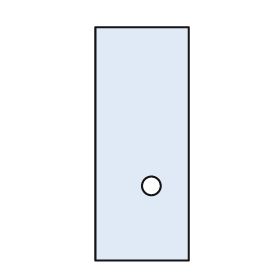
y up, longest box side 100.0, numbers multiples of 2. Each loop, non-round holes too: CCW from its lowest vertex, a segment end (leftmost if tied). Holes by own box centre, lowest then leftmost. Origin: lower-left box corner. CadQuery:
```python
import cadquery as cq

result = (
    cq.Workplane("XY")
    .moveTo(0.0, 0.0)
    .lineTo(40.0, 0.0)
    .lineTo(40.0, 100.0)
    .lineTo(0.0, 100.0)
    .close()
    .moveTo(24.0, 32.0)
    .circle(4.0)
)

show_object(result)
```